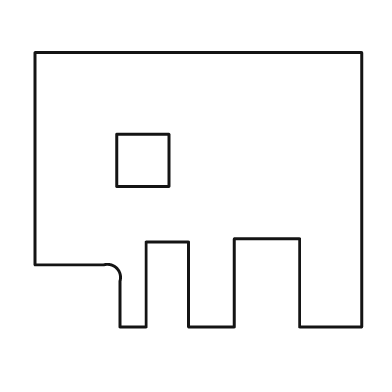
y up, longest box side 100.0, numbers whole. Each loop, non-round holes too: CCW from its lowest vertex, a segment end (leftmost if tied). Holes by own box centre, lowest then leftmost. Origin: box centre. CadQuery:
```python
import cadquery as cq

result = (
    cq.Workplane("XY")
    .moveTo(-24.0, -42.0)
    .lineTo(-16.0, -42.0)
    .lineTo(-16.0, -16.0)
    .lineTo(-3.0, -16.0)
    .lineTo(-3.0, -42.0)
    .lineTo(11.0, -42.0)
    .lineTo(11.0, -15.0)
    .lineTo(31.0, -15.0)
    .lineTo(31.0, -42.0)
    .lineTo(50.0, -42.0)
    .lineTo(50.0, 42.0)
    .lineTo(-50.0, 42.0)
    .lineTo(-50.0, -23.0)
    .lineTo(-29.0, -23.0)
    .threePointArc((-25.0, -24.0), (-24.0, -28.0))
    .close()
    .moveTo(-25.0, 1.0)
    .lineTo(-9.0, 1.0)
    .lineTo(-9.0, 17.0)
    .lineTo(-25.0, 17.0)
    .close()
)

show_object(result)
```